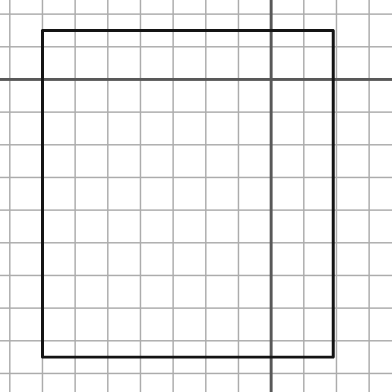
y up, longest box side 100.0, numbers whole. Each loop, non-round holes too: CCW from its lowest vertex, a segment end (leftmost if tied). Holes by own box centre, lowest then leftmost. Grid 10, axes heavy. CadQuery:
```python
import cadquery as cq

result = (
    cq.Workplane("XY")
    .moveTo(-70.0, -85.0)
    .lineTo(19.0, -85.0)
    .lineTo(19.0, 15.0)
    .lineTo(-70.0, 15.0)
    .close()
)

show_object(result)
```